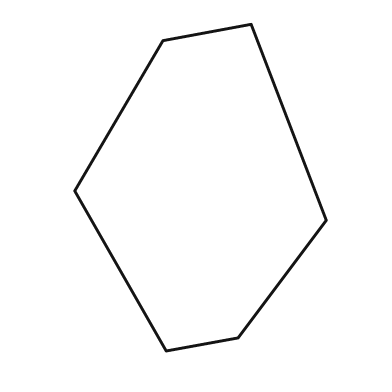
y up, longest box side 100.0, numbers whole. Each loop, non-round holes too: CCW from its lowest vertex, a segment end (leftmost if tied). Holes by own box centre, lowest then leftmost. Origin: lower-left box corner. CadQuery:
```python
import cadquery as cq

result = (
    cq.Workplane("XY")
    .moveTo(28.0, 0.0)
    .lineTo(50.0, 4.0)
    .lineTo(77.0, 40.0)
    .lineTo(54.0, 100.0)
    .lineTo(27.0, 95.0)
    .lineTo(0.0, 49.0)
    .close()
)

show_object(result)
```